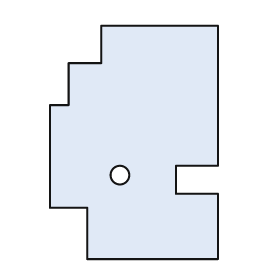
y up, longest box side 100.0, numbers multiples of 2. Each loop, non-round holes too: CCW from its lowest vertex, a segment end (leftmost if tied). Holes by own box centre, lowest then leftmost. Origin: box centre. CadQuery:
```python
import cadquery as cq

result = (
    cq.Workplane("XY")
    .moveTo(-20.0, -50.0)
    .lineTo(36.0, -50.0)
    .lineTo(36.0, -22.0)
    .lineTo(18.0, -22.0)
    .lineTo(18.0, -10.0)
    .lineTo(36.0, -10.0)
    .lineTo(36.0, 50.0)
    .lineTo(-14.0, 50.0)
    .lineTo(-14.0, 34.0)
    .lineTo(-28.0, 34.0)
    .lineTo(-28.0, 16.0)
    .lineTo(-36.0, 16.0)
    .lineTo(-36.0, -28.0)
    .lineTo(-20.0, -28.0)
    .close()
    .moveTo(-6.0, -14.0)
    .circle(4.0)
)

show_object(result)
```